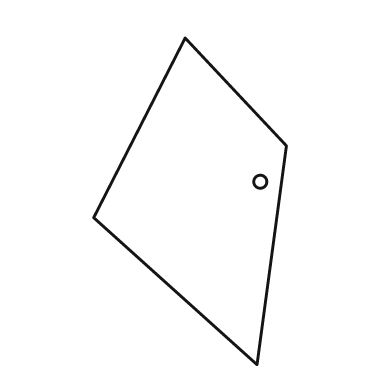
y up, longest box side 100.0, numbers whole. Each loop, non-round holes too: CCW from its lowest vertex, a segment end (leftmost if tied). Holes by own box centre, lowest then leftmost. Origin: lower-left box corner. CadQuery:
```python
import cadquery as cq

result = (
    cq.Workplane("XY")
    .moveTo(50.0, 0.0)
    .lineTo(59.0, 67.0)
    .lineTo(28.0, 100.0)
    .lineTo(0.0, 45.0)
    .close()
    .moveTo(51.0, 56.0)
    .circle(2.0)
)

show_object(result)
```